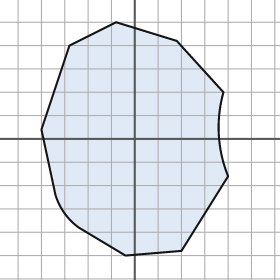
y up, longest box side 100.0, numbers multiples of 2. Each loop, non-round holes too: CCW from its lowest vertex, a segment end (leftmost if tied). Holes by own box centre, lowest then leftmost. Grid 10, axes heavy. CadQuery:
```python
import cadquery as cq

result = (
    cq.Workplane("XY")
    .moveTo(-4.0, -50.0)
    .lineTo(20.0, -48.0)
    .lineTo(40.0, -16.0)
    .threePointArc((36.0, 2.0), (38.0, 20.0))
    .lineTo(18.0, 42.0)
    .lineTo(-8.0, 50.0)
    .lineTo(-28.0, 40.0)
    .lineTo(-40.0, 4.0)
    .lineTo(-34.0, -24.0)
    .threePointArc((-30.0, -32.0), (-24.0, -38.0))
    .close()
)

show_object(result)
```